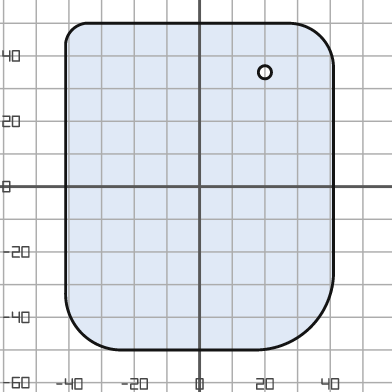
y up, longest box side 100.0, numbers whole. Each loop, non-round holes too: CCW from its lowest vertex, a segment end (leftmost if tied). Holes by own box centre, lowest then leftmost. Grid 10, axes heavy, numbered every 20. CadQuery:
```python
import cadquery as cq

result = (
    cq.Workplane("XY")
    .moveTo(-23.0, -50.0)
    .lineTo(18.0, -50.0)
    .threePointArc((34.0, -43.0), (41.0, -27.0))
    .lineTo(41.0, 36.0)
    .threePointArc((37.0, 46.0), (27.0, 50.0))
    .lineTo(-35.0, 50.0)
    .threePointArc((-39.0, 48.0), (-41.0, 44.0))
    .lineTo(-41.0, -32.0)
    .threePointArc((-36.0, -45.0), (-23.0, -50.0))
    .close()
    .moveTo(20.0, 35.0)
    .circle(2.0)
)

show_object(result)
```